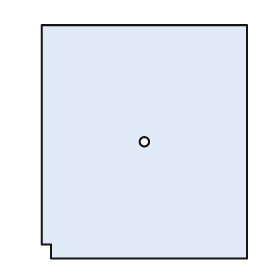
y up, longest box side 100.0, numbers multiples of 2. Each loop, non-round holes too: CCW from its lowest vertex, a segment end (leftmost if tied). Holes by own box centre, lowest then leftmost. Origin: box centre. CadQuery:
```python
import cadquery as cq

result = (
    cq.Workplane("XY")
    .moveTo(-40.0, -50.0)
    .lineTo(44.0, -50.0)
    .lineTo(44.0, 50.0)
    .lineTo(-44.0, 50.0)
    .lineTo(-44.0, -44.0)
    .lineTo(-40.0, -44.0)
    .close()
    .moveTo(0.0, 0.0)
    .circle(2.0)
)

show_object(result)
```